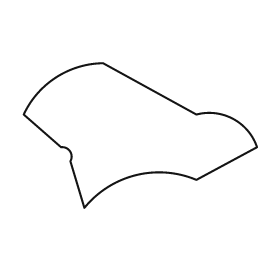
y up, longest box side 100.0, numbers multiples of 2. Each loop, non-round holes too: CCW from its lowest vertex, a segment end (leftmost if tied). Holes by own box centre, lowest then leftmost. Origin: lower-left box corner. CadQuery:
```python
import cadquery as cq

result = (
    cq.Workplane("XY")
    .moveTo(26.0, 0.0)
    .threePointArc((48.0, 14.0), (74.0, 12.0))
    .lineTo(100.0, 26.0)
    .threePointArc((90.0, 38.0), (74.0, 40.0))
    .lineTo(34.0, 62.0)
    .threePointArc((14.0, 56.0), (0.0, 40.0))
    .lineTo(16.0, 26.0)
    .threePointArc((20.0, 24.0), (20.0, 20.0))
    .close()
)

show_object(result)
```